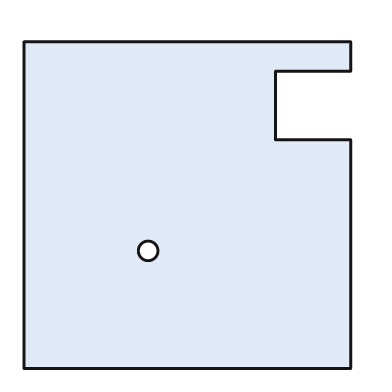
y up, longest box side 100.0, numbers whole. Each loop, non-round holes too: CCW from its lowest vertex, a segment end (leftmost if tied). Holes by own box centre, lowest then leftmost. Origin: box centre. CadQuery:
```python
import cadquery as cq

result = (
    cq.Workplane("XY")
    .moveTo(-50.0, -50.0)
    .lineTo(50.0, -50.0)
    .lineTo(50.0, 20.0)
    .lineTo(27.0, 20.0)
    .lineTo(27.0, 41.0)
    .lineTo(50.0, 41.0)
    .lineTo(50.0, 50.0)
    .lineTo(-50.0, 50.0)
    .close()
    .moveTo(-12.0, -14.0)
    .circle(3.0)
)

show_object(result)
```